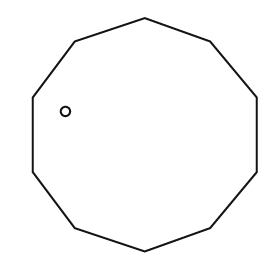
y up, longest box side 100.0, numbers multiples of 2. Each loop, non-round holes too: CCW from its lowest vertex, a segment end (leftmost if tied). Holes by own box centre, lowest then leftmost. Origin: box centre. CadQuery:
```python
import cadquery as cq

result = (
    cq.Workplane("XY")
    .moveTo(0.0, -50.0)
    .lineTo(28.0, -40.0)
    .lineTo(48.0, -16.0)
    .lineTo(48.0, 16.0)
    .lineTo(28.0, 40.0)
    .lineTo(0.0, 50.0)
    .lineTo(-30.0, 40.0)
    .lineTo(-48.0, 16.0)
    .lineTo(-48.0, -16.0)
    .lineTo(-30.0, -40.0)
    .close()
    .moveTo(-34.0, 10.0)
    .circle(2.0)
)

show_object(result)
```